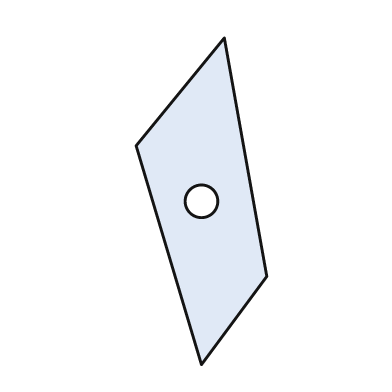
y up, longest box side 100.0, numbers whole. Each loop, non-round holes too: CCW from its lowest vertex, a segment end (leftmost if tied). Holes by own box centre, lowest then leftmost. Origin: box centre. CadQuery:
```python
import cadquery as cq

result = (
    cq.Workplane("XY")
    .moveTo(0.0, -50.0)
    .lineTo(20.0, -23.0)
    .lineTo(7.0, 50.0)
    .lineTo(-20.0, 17.0)
    .close()
    .moveTo(0.0, 0.0)
    .circle(5.0)
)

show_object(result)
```